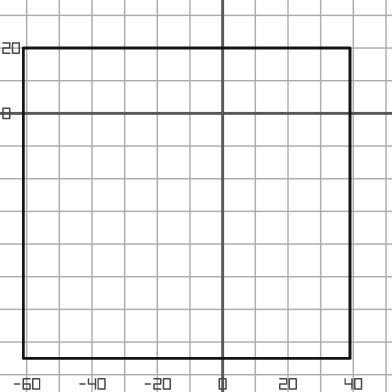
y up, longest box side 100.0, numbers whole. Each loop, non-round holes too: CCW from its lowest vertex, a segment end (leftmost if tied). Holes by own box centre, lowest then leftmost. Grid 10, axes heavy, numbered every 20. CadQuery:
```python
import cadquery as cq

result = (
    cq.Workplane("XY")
    .moveTo(-61.0, -75.0)
    .lineTo(39.0, -75.0)
    .lineTo(39.0, 20.0)
    .lineTo(-61.0, 20.0)
    .close()
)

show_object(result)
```